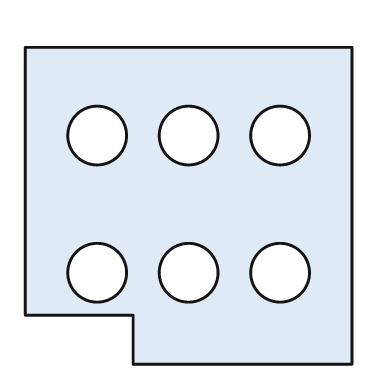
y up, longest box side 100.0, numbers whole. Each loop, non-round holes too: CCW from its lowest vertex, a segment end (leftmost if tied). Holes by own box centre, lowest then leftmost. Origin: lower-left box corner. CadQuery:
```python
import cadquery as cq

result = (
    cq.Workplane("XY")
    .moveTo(33.0, 0.0)
    .lineTo(100.0, 0.0)
    .lineTo(100.0, 97.0)
    .lineTo(0.0, 97.0)
    .lineTo(0.0, 15.0)
    .lineTo(33.0, 15.0)
    .close()
    .moveTo(22.0, 28.0)
    .circle(9.0)
    .moveTo(50.0, 28.0)
    .circle(9.0)
    .moveTo(78.0, 28.0)
    .circle(9.0)
    .moveTo(22.0, 70.0)
    .circle(9.0)
    .moveTo(50.0, 70.0)
    .circle(9.0)
    .moveTo(78.0, 70.0)
    .circle(9.0)
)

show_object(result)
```